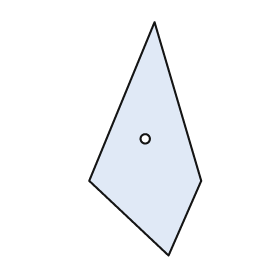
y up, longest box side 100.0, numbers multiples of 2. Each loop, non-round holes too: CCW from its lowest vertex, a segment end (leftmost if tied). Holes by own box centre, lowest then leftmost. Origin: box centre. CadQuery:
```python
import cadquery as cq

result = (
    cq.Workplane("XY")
    .moveTo(10.0, -50.0)
    .lineTo(24.0, -18.0)
    .lineTo(4.0, 50.0)
    .lineTo(-24.0, -18.0)
    .close()
    .moveTo(0.0, 0.0)
    .circle(2.0)
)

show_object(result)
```